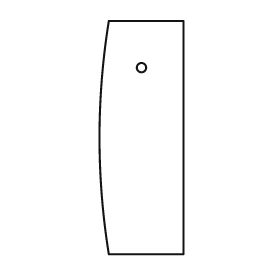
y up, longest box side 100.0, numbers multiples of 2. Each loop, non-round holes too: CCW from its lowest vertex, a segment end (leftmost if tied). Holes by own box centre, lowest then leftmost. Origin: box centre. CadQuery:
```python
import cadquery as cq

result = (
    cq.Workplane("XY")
    .moveTo(-14.0, -50.0)
    .lineTo(18.0, -50.0)
    .lineTo(18.0, 50.0)
    .lineTo(-14.0, 50.0)
    .threePointArc((-18.0, 0.0), (-14.0, -50.0))
    .close()
    .moveTo(0.0, 30.0)
    .circle(2.0)
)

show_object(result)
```